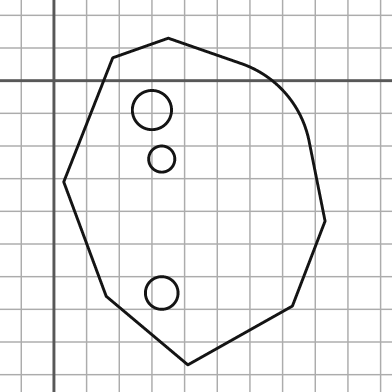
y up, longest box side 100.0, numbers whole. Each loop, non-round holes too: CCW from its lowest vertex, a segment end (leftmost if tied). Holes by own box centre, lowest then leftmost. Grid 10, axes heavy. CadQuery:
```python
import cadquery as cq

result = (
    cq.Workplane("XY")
    .moveTo(41.0, -87.0)
    .lineTo(73.0, -69.0)
    .lineTo(83.0, -43.0)
    .lineTo(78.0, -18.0)
    .threePointArc((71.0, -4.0), (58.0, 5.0))
    .lineTo(35.0, 13.0)
    .lineTo(18.0, 7.0)
    .lineTo(3.0, -31.0)
    .lineTo(16.0, -66.0)
    .close()
    .moveTo(33.0, -65.0)
    .circle(5.0)
    .moveTo(33.0, -24.0)
    .circle(4.0)
    .moveTo(30.0, -9.0)
    .circle(6.0)
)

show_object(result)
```